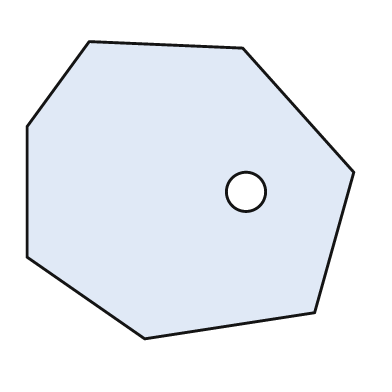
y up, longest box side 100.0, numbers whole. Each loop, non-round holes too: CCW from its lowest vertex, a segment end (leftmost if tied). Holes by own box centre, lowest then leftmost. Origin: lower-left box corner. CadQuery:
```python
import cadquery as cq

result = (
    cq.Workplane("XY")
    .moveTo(36.0, 0.0)
    .lineTo(88.0, 8.0)
    .lineTo(100.0, 51.0)
    .lineTo(66.0, 89.0)
    .lineTo(19.0, 91.0)
    .lineTo(0.0, 65.0)
    .lineTo(0.0, 25.0)
    .close()
    .moveTo(67.0, 45.0)
    .circle(6.0)
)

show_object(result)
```